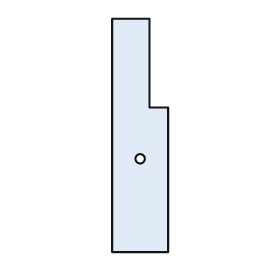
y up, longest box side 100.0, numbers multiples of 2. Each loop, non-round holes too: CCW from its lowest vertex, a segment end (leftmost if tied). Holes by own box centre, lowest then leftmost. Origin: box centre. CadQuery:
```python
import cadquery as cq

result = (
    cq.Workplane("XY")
    .moveTo(-12.0, -50.0)
    .lineTo(12.0, -50.0)
    .lineTo(12.0, 12.0)
    .lineTo(4.0, 12.0)
    .lineTo(4.0, 50.0)
    .lineTo(-12.0, 50.0)
    .close()
    .moveTo(0.0, -10.0)
    .circle(2.0)
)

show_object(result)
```